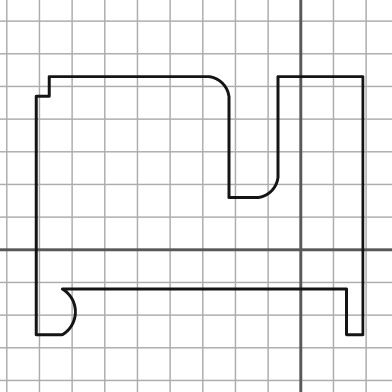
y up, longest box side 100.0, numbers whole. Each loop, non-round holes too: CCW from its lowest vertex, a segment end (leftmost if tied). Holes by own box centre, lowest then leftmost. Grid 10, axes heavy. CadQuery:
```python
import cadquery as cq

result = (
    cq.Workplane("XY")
    .moveTo(-81.0, -26.0)
    .lineTo(-73.0, -26.0)
    .threePointArc((-69.0, -19.0), (-73.0, -12.0))
    .lineTo(14.0, -12.0)
    .lineTo(14.0, -26.0)
    .lineTo(19.0, -26.0)
    .lineTo(19.0, 53.0)
    .lineTo(-7.0, 53.0)
    .lineTo(-7.0, 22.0)
    .threePointArc((-9.0, 18.0), (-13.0, 16.0))
    .lineTo(-22.0, 16.0)
    .lineTo(-22.0, 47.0)
    .threePointArc((-24.0, 51.0), (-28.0, 53.0))
    .lineTo(-77.0, 53.0)
    .lineTo(-77.0, 47.0)
    .lineTo(-81.0, 47.0)
    .close()
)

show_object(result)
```